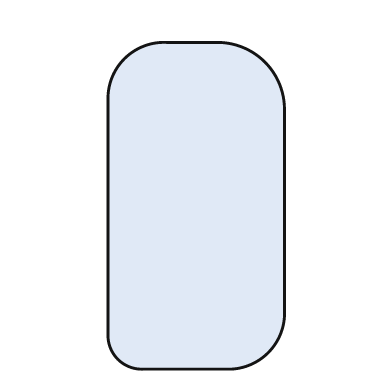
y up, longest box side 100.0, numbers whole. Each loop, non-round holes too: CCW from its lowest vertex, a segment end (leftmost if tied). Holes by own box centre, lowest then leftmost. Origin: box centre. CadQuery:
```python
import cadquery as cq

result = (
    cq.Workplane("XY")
    .moveTo(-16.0, -50.0)
    .lineTo(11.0, -50.0)
    .threePointArc((22.0, -45.0), (27.0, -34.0))
    .lineTo(27.0, 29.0)
    .threePointArc((21.0, 44.0), (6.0, 50.0))
    .lineTo(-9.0, 50.0)
    .threePointArc((-22.0, 45.0), (-27.0, 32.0))
    .lineTo(-27.0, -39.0)
    .threePointArc((-24.0, -47.0), (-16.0, -50.0))
    .close()
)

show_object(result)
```